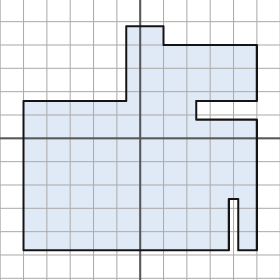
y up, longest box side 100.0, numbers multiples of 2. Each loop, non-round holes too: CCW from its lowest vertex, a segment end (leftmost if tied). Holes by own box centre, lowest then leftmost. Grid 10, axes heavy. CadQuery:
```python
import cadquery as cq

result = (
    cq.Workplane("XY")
    .moveTo(-50.0, -48.0)
    .lineTo(38.0, -48.0)
    .lineTo(38.0, -26.0)
    .lineTo(42.0, -26.0)
    .lineTo(42.0, -48.0)
    .lineTo(50.0, -48.0)
    .lineTo(50.0, 8.0)
    .lineTo(24.0, 8.0)
    .lineTo(24.0, 16.0)
    .lineTo(50.0, 16.0)
    .lineTo(50.0, 40.0)
    .lineTo(10.0, 40.0)
    .lineTo(10.0, 48.0)
    .lineTo(-6.0, 48.0)
    .lineTo(-6.0, 16.0)
    .lineTo(-50.0, 16.0)
    .close()
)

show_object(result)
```